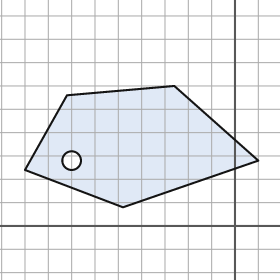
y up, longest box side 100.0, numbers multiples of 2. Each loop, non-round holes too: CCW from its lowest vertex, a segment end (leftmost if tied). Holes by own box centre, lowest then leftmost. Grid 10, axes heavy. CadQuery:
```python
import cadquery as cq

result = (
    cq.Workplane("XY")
    .moveTo(-48.0, 8.0)
    .lineTo(10.0, 28.0)
    .lineTo(-26.0, 60.0)
    .lineTo(-72.0, 56.0)
    .lineTo(-90.0, 24.0)
    .close()
    .moveTo(-70.0, 28.0)
    .circle(4.0)
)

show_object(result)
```